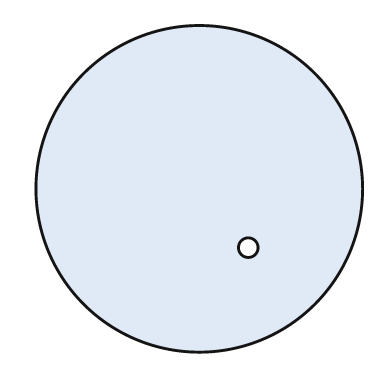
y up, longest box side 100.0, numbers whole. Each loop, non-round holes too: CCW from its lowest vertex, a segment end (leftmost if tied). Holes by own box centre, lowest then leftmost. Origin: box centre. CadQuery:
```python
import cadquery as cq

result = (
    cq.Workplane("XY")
    .moveTo(0.0, 0.0)
    .circle(50.0)
    .moveTo(15.0, -18.0)
    .circle(3.0)
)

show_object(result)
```